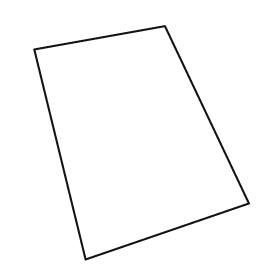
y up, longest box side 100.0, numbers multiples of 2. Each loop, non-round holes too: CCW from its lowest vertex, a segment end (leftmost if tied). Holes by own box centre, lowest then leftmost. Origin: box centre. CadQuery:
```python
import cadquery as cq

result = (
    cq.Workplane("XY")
    .moveTo(-24.0, -50.0)
    .lineTo(46.0, -26.0)
    .lineTo(10.0, 50.0)
    .lineTo(-46.0, 40.0)
    .close()
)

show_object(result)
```